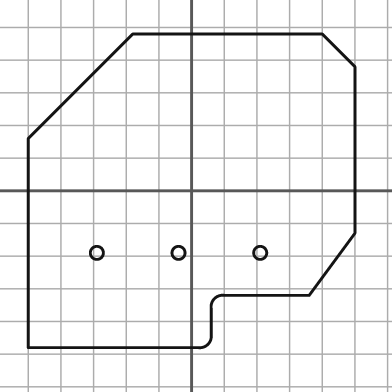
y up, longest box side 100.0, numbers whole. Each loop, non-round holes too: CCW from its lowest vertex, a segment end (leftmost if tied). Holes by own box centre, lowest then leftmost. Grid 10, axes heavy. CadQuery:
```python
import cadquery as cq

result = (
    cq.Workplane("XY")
    .moveTo(-50.0, -48.0)
    .lineTo(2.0, -48.0)
    .threePointArc((5.0, -47.0), (6.0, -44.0))
    .lineTo(6.0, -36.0)
    .threePointArc((7.0, -33.0), (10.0, -32.0))
    .lineTo(36.0, -32.0)
    .lineTo(50.0, -13.0)
    .lineTo(50.0, 38.0)
    .lineTo(40.0, 48.0)
    .lineTo(-18.0, 48.0)
    .lineTo(-50.0, 16.0)
    .close()
    .moveTo(-29.0, -19.0)
    .circle(2.0)
    .moveTo(-4.0, -19.0)
    .circle(2.0)
    .moveTo(21.0, -19.0)
    .circle(2.0)
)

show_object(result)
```